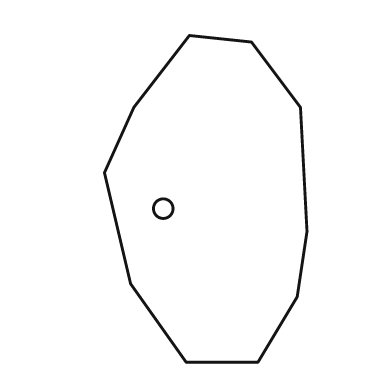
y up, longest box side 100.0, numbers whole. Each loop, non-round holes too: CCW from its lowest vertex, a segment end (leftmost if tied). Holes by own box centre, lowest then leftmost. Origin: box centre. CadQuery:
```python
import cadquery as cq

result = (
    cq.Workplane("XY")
    .moveTo(-6.0, -50.0)
    .lineTo(16.0, -50.0)
    .lineTo(28.0, -30.0)
    .lineTo(31.0, -10.0)
    .lineTo(29.0, 28.0)
    .lineTo(14.0, 48.0)
    .lineTo(-5.0, 50.0)
    .lineTo(-22.0, 28.0)
    .lineTo(-31.0, 8.0)
    .lineTo(-23.0, -26.0)
    .close()
    .moveTo(-13.0, -3.0)
    .circle(3.0)
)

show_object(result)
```